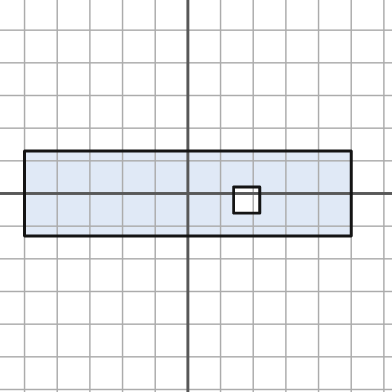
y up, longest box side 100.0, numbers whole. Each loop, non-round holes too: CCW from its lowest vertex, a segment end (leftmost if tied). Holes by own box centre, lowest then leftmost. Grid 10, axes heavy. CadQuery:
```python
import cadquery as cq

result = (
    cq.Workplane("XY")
    .moveTo(-50.0, -13.0)
    .lineTo(50.0, -13.0)
    .lineTo(50.0, 13.0)
    .lineTo(-50.0, 13.0)
    .close()
    .moveTo(14.0, -6.0)
    .lineTo(22.0, -6.0)
    .lineTo(22.0, 2.0)
    .lineTo(14.0, 2.0)
    .close()
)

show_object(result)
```